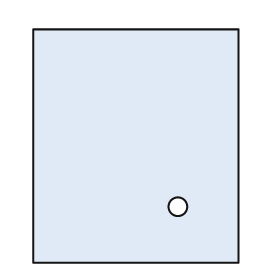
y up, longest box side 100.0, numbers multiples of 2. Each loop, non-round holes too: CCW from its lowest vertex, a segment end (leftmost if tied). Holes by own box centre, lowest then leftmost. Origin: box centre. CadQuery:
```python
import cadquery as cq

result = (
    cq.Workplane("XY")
    .moveTo(-44.0, -50.0)
    .lineTo(44.0, -50.0)
    .lineTo(44.0, 50.0)
    .lineTo(-44.0, 50.0)
    .close()
    .moveTo(18.0, -26.0)
    .circle(4.0)
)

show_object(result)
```